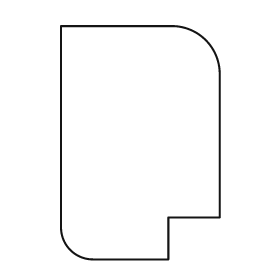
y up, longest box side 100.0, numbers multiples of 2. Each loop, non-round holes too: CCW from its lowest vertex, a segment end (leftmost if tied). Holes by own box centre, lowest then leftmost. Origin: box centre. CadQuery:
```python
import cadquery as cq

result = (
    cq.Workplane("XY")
    .moveTo(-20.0, -50.0)
    .lineTo(12.0, -50.0)
    .lineTo(12.0, -32.0)
    .lineTo(34.0, -32.0)
    .lineTo(34.0, 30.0)
    .threePointArc((28.0, 44.0), (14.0, 50.0))
    .lineTo(-34.0, 50.0)
    .lineTo(-34.0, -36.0)
    .threePointArc((-30.0, -46.0), (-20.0, -50.0))
    .close()
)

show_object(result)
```